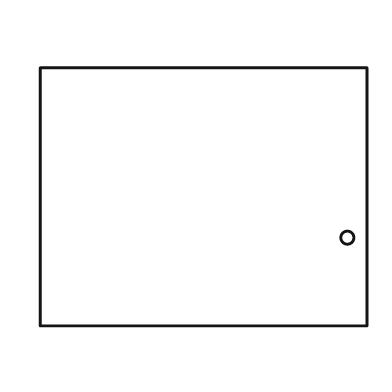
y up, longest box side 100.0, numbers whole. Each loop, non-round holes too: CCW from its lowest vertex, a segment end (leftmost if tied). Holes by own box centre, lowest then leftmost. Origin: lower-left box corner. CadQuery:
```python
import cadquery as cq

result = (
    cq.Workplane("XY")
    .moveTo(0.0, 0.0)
    .lineTo(100.0, 0.0)
    .lineTo(100.0, 79.0)
    .lineTo(0.0, 79.0)
    .close()
    .moveTo(94.0, 27.0)
    .circle(2.0)
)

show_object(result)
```